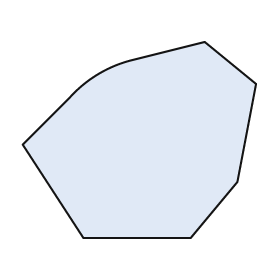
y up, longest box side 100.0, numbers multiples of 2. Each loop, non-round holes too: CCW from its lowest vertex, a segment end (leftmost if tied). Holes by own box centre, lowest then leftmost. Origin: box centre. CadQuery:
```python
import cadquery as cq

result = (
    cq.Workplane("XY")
    .moveTo(-24.0, -42.0)
    .lineTo(22.0, -42.0)
    .lineTo(42.0, -18.0)
    .lineTo(50.0, 24.0)
    .lineTo(28.0, 42.0)
    .lineTo(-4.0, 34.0)
    .threePointArc((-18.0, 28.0), (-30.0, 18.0))
    .lineTo(-50.0, -2.0)
    .close()
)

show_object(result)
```